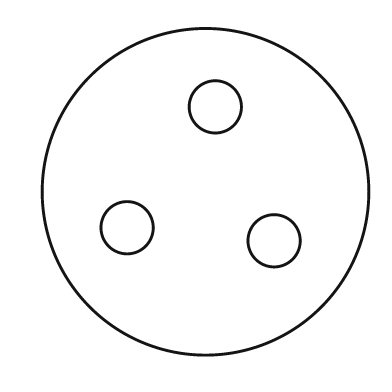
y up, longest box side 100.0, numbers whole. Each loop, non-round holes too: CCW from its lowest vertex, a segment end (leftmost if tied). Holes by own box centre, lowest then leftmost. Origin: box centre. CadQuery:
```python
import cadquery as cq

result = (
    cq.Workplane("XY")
    .moveTo(0.0, 0.0)
    .circle(50.0)
    .moveTo(21.0, -15.0)
    .circle(8.0)
    .moveTo(-24.0, -11.0)
    .circle(8.0)
    .moveTo(3.0, 26.0)
    .circle(8.0)
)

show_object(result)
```